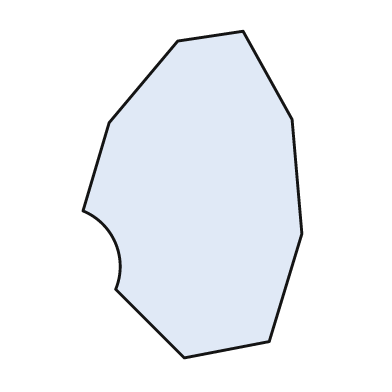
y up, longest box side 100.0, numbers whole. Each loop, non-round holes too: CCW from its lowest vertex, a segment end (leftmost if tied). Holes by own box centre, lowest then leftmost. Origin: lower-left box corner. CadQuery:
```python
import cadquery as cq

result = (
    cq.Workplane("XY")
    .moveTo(31.0, 0.0)
    .lineTo(57.0, 5.0)
    .lineTo(67.0, 38.0)
    .lineTo(64.0, 73.0)
    .lineTo(49.0, 100.0)
    .lineTo(29.0, 97.0)
    .lineTo(8.0, 72.0)
    .lineTo(0.0, 45.0)
    .threePointArc((10.0, 35.0), (10.0, 21.0))
    .close()
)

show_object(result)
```